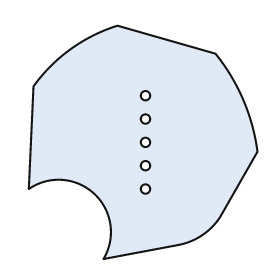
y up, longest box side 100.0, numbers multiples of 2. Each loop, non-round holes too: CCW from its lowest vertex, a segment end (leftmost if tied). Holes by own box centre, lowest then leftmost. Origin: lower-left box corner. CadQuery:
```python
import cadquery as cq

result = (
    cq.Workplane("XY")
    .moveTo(32.0, 0.0)
    .lineTo(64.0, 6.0)
    .threePointArc((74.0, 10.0), (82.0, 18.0))
    .lineTo(98.0, 46.0)
    .threePointArc((92.0, 68.0), (80.0, 88.0))
    .lineTo(38.0, 100.0)
    .threePointArc((18.0, 90.0), (2.0, 74.0))
    .lineTo(0.0, 30.0)
    .threePointArc((28.0, 28.0), (32.0, 0.0))
    .close()
    .moveTo(50.0, 30.0)
    .circle(2.0)
    .moveTo(50.0, 40.0)
    .circle(2.0)
    .moveTo(50.0, 50.0)
    .circle(2.0)
    .moveTo(50.0, 60.0)
    .circle(2.0)
    .moveTo(50.0, 70.0)
    .circle(2.0)
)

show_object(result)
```